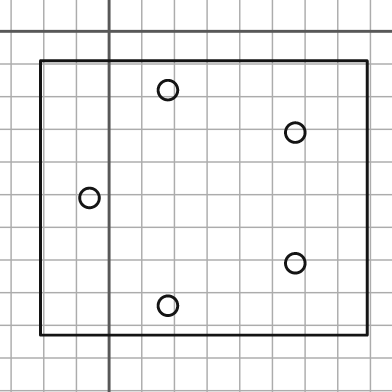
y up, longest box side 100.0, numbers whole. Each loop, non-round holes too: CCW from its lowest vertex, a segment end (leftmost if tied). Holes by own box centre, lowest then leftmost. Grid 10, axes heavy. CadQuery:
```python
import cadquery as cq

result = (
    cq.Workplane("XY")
    .moveTo(-21.0, -93.0)
    .lineTo(79.0, -93.0)
    .lineTo(79.0, -9.0)
    .lineTo(-21.0, -9.0)
    .close()
    .moveTo(18.0, -84.0)
    .circle(3.0)
    .moveTo(57.0, -71.0)
    .circle(3.0)
    .moveTo(-6.0, -51.0)
    .circle(3.0)
    .moveTo(57.0, -31.0)
    .circle(3.0)
    .moveTo(18.0, -18.0)
    .circle(3.0)
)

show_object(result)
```